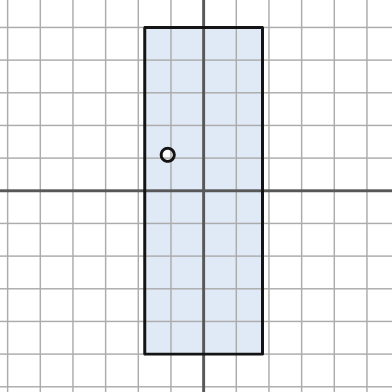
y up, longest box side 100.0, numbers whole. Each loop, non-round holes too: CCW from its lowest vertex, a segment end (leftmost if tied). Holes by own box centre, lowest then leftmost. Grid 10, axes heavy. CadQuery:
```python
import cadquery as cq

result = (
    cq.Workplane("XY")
    .moveTo(-18.0, -50.0)
    .lineTo(18.0, -50.0)
    .lineTo(18.0, 50.0)
    .lineTo(-18.0, 50.0)
    .close()
    .moveTo(-11.0, 11.0)
    .circle(2.0)
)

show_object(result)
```